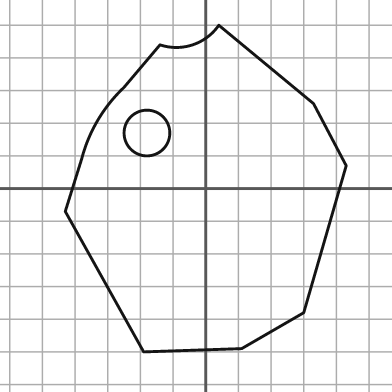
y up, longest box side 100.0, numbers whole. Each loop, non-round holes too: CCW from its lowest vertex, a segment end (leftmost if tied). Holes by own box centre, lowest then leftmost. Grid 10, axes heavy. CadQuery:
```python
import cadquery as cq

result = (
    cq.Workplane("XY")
    .moveTo(-19.0, -50.0)
    .lineTo(11.0, -49.0)
    .lineTo(30.0, -38.0)
    .lineTo(43.0, 7.0)
    .lineTo(33.0, 26.0)
    .lineTo(4.0, 50.0)
    .threePointArc((-4.0, 44.0), (-14.0, 44.0))
    .lineTo(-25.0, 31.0)
    .threePointArc((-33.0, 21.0), (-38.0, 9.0))
    .lineTo(-43.0, -7.0)
    .close()
    .moveTo(-18.0, 17.0)
    .circle(7.0)
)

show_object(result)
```